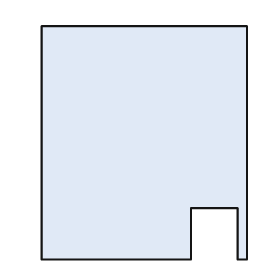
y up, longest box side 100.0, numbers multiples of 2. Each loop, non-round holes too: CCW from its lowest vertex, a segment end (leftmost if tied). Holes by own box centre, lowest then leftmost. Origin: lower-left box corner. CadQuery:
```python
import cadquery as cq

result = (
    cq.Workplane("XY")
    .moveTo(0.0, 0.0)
    .lineTo(64.0, 0.0)
    .lineTo(64.0, 22.0)
    .lineTo(84.0, 22.0)
    .lineTo(84.0, 0.0)
    .lineTo(88.0, 0.0)
    .lineTo(88.0, 100.0)
    .lineTo(0.0, 100.0)
    .close()
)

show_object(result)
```